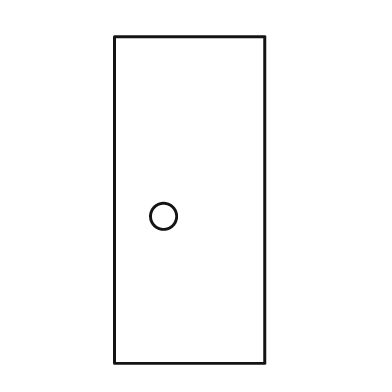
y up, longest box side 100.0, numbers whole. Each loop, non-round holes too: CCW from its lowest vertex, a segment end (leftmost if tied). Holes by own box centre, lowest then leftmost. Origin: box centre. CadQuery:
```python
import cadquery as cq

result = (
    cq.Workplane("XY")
    .moveTo(-23.0, -50.0)
    .lineTo(23.0, -50.0)
    .lineTo(23.0, 50.0)
    .lineTo(-23.0, 50.0)
    .close()
    .moveTo(-8.0, -5.0)
    .circle(4.0)
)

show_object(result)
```